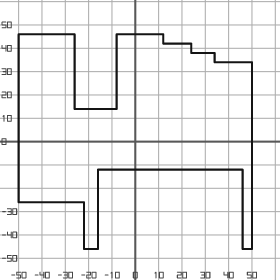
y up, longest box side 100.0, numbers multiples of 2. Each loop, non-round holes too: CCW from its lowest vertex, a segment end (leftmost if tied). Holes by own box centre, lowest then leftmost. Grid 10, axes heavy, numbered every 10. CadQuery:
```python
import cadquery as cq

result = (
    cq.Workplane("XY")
    .moveTo(-22.0, -46.0)
    .lineTo(-16.0, -46.0)
    .lineTo(-16.0, -12.0)
    .lineTo(46.0, -12.0)
    .lineTo(46.0, -46.0)
    .lineTo(50.0, -46.0)
    .lineTo(50.0, 34.0)
    .lineTo(34.0, 34.0)
    .lineTo(34.0, 38.0)
    .lineTo(24.0, 38.0)
    .lineTo(24.0, 42.0)
    .lineTo(12.0, 42.0)
    .lineTo(12.0, 46.0)
    .lineTo(-8.0, 46.0)
    .lineTo(-8.0, 14.0)
    .lineTo(-26.0, 14.0)
    .lineTo(-26.0, 46.0)
    .lineTo(-50.0, 46.0)
    .lineTo(-50.0, -26.0)
    .lineTo(-22.0, -26.0)
    .close()
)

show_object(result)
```